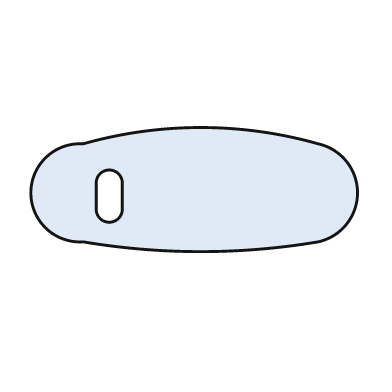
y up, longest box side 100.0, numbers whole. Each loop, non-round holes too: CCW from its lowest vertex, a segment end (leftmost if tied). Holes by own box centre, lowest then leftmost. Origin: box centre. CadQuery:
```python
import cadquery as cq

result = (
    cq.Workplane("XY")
    .moveTo(-34.0, -16.0)
    .threePointArc((2.0, -19.0), (38.0, -16.0))
    .threePointArc((50.0, -1.0), (38.0, 14.0))
    .threePointArc((2.0, 19.0), (-34.0, 14.0))
    .threePointArc((-50.0, -1.0), (-34.0, -16.0))
    .close()
    .moveTo(-30.0, -6.0)
    .threePointArc((-26.0, -10.0), (-22.0, -6.0))
    .lineTo(-22.0, 2.0)
    .threePointArc((-26.0, 6.0), (-30.0, 2.0))
    .close()
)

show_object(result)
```